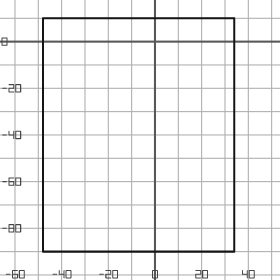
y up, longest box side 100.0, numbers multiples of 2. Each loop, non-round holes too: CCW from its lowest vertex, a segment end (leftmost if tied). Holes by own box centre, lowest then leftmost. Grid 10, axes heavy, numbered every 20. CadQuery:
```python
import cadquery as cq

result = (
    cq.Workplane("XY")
    .moveTo(-48.0, -90.0)
    .lineTo(34.0, -90.0)
    .lineTo(34.0, 10.0)
    .lineTo(-48.0, 10.0)
    .close()
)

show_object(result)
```